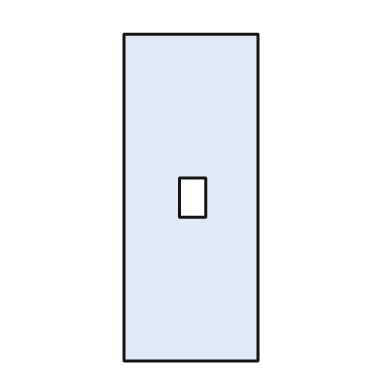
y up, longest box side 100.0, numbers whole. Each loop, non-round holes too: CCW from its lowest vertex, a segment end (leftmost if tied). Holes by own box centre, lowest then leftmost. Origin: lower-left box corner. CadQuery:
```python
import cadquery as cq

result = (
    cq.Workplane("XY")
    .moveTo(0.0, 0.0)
    .lineTo(41.0, 0.0)
    .lineTo(41.0, 100.0)
    .lineTo(0.0, 100.0)
    .close()
    .moveTo(17.0, 44.0)
    .lineTo(25.0, 44.0)
    .lineTo(25.0, 56.0)
    .lineTo(17.0, 56.0)
    .close()
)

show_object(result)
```